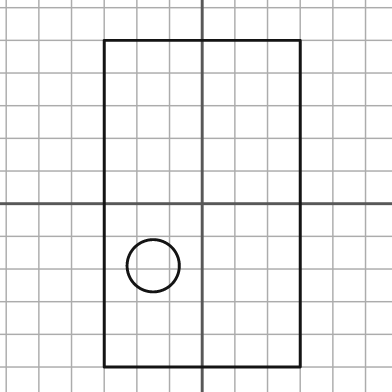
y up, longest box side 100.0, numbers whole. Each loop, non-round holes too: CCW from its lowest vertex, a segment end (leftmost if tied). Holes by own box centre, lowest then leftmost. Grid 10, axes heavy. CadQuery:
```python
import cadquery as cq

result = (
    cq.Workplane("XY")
    .moveTo(-30.0, -50.0)
    .lineTo(30.0, -50.0)
    .lineTo(30.0, 50.0)
    .lineTo(-30.0, 50.0)
    .close()
    .moveTo(-15.0, -19.0)
    .circle(8.0)
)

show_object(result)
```